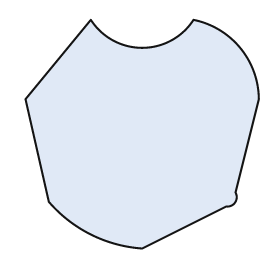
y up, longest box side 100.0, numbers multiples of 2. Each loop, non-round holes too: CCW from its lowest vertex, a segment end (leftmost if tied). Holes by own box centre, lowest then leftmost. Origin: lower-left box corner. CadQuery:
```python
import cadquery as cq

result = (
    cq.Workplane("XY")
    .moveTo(50.0, 0.0)
    .lineTo(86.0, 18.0)
    .threePointArc((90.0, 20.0), (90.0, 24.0))
    .lineTo(100.0, 64.0)
    .threePointArc((92.0, 86.0), (72.0, 98.0))
    .threePointArc((50.0, 86.0), (28.0, 98.0))
    .lineTo(0.0, 64.0)
    .lineTo(10.0, 20.0)
    .threePointArc((28.0, 6.0), (50.0, 0.0))
    .close()
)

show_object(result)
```